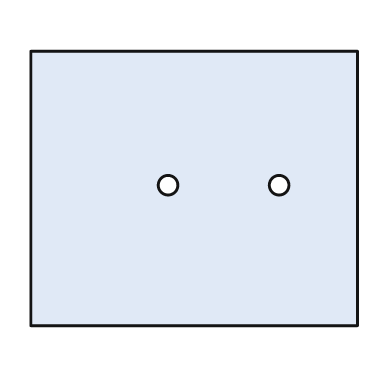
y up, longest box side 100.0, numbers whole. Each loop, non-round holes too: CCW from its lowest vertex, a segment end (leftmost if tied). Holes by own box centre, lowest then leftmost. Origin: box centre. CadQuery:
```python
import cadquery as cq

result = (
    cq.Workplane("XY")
    .moveTo(-50.0, -42.0)
    .lineTo(50.0, -42.0)
    .lineTo(50.0, 42.0)
    .lineTo(-50.0, 42.0)
    .close()
    .moveTo(-8.0, 1.0)
    .circle(3.0)
    .moveTo(26.0, 1.0)
    .circle(3.0)
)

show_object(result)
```